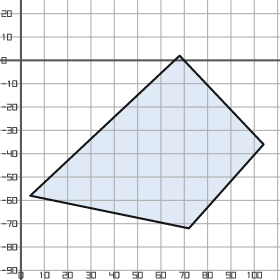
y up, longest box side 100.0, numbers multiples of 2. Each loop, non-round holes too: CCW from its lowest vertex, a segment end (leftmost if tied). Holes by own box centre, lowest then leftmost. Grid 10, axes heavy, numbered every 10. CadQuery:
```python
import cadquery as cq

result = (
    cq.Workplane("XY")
    .moveTo(72.0, -72.0)
    .lineTo(104.0, -36.0)
    .lineTo(68.0, 2.0)
    .lineTo(4.0, -58.0)
    .close()
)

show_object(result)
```